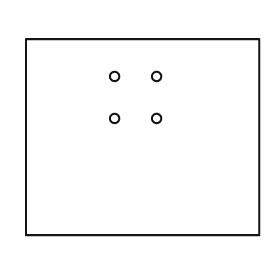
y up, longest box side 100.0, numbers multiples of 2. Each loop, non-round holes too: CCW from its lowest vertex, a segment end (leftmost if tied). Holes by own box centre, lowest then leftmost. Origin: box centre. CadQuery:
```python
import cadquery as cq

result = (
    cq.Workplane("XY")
    .moveTo(-50.0, -42.0)
    .lineTo(50.0, -42.0)
    .lineTo(50.0, 42.0)
    .lineTo(-50.0, 42.0)
    .close()
    .moveTo(-12.0, 8.0)
    .circle(2.0)
    .moveTo(6.0, 8.0)
    .circle(2.0)
    .moveTo(-12.0, 26.0)
    .circle(2.0)
    .moveTo(6.0, 26.0)
    .circle(2.0)
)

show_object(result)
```